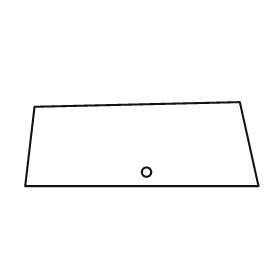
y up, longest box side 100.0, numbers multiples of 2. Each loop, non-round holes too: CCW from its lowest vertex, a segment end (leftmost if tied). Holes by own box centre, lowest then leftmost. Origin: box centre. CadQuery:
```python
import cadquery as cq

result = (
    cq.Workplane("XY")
    .moveTo(-50.0, -18.0)
    .lineTo(50.0, -18.0)
    .lineTo(42.0, 18.0)
    .lineTo(-46.0, 16.0)
    .close()
    .moveTo(2.0, -12.0)
    .circle(2.0)
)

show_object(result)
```